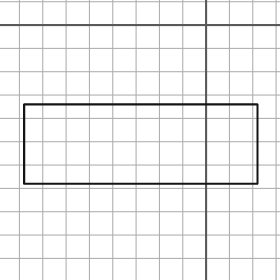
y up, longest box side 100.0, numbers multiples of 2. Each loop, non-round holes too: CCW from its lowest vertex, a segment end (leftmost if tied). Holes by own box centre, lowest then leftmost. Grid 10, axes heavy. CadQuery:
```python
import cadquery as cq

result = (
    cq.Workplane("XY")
    .moveTo(-78.0, -68.0)
    .lineTo(22.0, -68.0)
    .lineTo(22.0, -34.0)
    .lineTo(-78.0, -34.0)
    .close()
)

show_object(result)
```